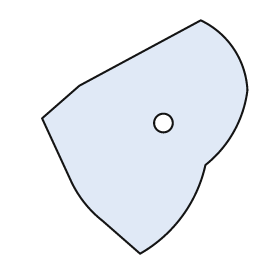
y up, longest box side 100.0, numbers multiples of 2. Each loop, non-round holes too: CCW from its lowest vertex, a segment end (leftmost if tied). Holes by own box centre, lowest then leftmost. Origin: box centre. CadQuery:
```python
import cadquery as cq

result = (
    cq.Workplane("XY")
    .moveTo(-2.0, -50.0)
    .threePointArc((16.0, -34.0), (26.0, -12.0))
    .threePointArc((38.0, 2.0), (44.0, 20.0))
    .threePointArc((38.0, 38.0), (24.0, 50.0))
    .lineTo(-28.0, 22.0)
    .lineTo(-44.0, 8.0)
    .lineTo(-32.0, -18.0)
    .threePointArc((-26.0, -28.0), (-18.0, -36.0))
    .close()
    .moveTo(8.0, 6.0)
    .circle(4.0)
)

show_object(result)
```